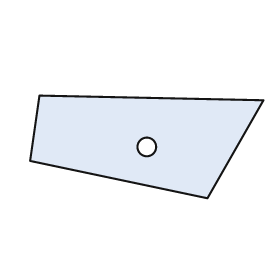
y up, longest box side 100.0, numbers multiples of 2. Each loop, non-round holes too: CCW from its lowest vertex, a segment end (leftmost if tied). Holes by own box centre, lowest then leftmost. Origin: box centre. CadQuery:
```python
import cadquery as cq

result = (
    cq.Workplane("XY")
    .moveTo(26.0, -22.0)
    .lineTo(50.0, 20.0)
    .lineTo(-46.0, 22.0)
    .lineTo(-50.0, -6.0)
    .close()
    .moveTo(0.0, 0.0)
    .circle(4.0)
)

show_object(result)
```